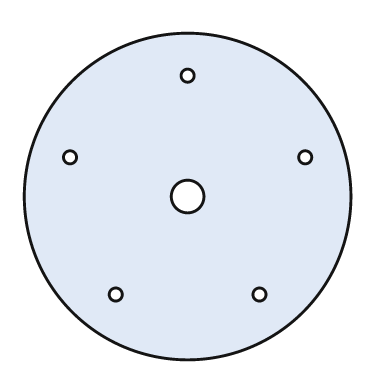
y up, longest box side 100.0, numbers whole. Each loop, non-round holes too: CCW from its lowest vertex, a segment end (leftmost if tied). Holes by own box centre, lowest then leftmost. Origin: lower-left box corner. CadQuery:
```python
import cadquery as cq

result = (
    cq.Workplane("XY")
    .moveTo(50.0, 50.0)
    .circle(50.0)
    .moveTo(28.0, 20.0)
    .circle(2.0)
    .moveTo(72.0, 20.0)
    .circle(2.0)
    .moveTo(50.0, 50.0)
    .circle(5.0)
    .moveTo(14.0, 62.0)
    .circle(2.0)
    .moveTo(86.0, 62.0)
    .circle(2.0)
    .moveTo(50.0, 87.0)
    .circle(2.0)
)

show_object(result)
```